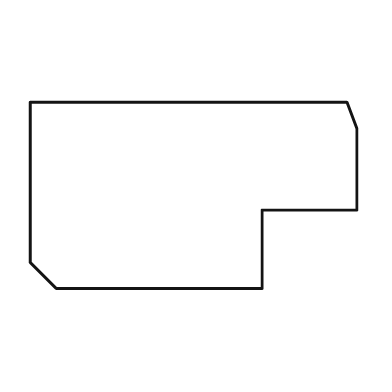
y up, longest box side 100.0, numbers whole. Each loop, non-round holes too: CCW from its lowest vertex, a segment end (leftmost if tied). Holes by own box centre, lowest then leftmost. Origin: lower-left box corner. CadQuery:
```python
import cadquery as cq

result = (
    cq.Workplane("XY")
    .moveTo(8.0, 0.0)
    .lineTo(71.0, 0.0)
    .lineTo(71.0, 24.0)
    .lineTo(100.0, 24.0)
    .lineTo(100.0, 49.0)
    .lineTo(97.0, 57.0)
    .lineTo(0.0, 57.0)
    .lineTo(0.0, 8.0)
    .close()
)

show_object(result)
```